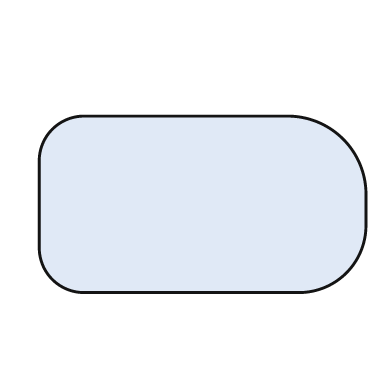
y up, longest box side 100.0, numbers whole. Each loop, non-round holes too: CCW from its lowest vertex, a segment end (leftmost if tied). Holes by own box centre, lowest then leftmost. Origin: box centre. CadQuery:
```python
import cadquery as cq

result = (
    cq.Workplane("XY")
    .moveTo(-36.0, -27.0)
    .lineTo(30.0, -27.0)
    .threePointArc((44.0, -21.0), (50.0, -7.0))
    .lineTo(50.0, 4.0)
    .threePointArc((43.0, 20.0), (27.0, 27.0))
    .lineTo(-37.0, 27.0)
    .threePointArc((-46.0, 23.0), (-50.0, 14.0))
    .lineTo(-50.0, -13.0)
    .threePointArc((-46.0, -23.0), (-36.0, -27.0))
    .close()
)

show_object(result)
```